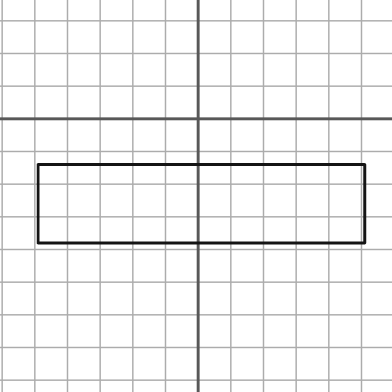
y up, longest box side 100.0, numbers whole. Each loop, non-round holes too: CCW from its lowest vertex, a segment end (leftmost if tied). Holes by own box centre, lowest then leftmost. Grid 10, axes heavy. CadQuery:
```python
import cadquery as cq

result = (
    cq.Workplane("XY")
    .moveTo(-49.0, -38.0)
    .lineTo(51.0, -38.0)
    .lineTo(51.0, -14.0)
    .lineTo(-49.0, -14.0)
    .close()
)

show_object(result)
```